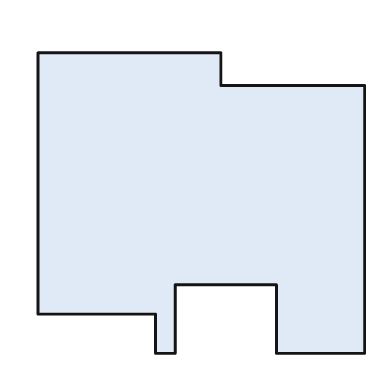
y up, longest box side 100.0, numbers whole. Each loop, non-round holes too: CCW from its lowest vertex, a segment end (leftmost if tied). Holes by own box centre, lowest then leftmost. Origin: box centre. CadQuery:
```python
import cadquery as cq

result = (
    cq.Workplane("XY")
    .moveTo(-14.0, -46.0)
    .lineTo(-8.0, -46.0)
    .lineTo(-8.0, -25.0)
    .lineTo(23.0, -25.0)
    .lineTo(23.0, -46.0)
    .lineTo(50.0, -46.0)
    .lineTo(50.0, 36.0)
    .lineTo(6.0, 36.0)
    .lineTo(6.0, 46.0)
    .lineTo(-50.0, 46.0)
    .lineTo(-50.0, -34.0)
    .lineTo(-14.0, -34.0)
    .close()
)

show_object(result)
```